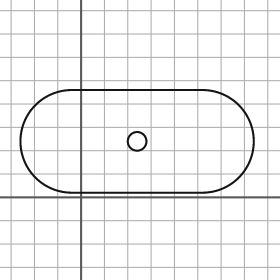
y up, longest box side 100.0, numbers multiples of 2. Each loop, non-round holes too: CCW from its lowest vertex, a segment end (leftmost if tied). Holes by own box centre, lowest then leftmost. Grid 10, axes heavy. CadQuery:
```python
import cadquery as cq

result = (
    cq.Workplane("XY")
    .moveTo(-4.0, 2.0)
    .lineTo(52.0, 2.0)
    .threePointArc((74.0, 24.0), (52.0, 46.0))
    .lineTo(-4.0, 46.0)
    .threePointArc((-26.0, 24.0), (-4.0, 2.0))
    .close()
    .moveTo(24.0, 24.0)
    .circle(4.0)
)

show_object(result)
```